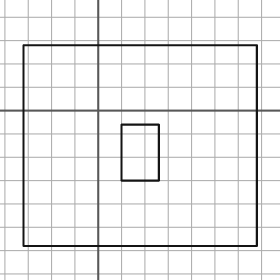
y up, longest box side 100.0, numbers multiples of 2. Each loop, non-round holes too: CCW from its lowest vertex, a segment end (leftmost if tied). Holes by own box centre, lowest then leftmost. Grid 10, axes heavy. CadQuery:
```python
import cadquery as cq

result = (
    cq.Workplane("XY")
    .moveTo(-32.0, -58.0)
    .lineTo(68.0, -58.0)
    .lineTo(68.0, 28.0)
    .lineTo(-32.0, 28.0)
    .close()
    .moveTo(10.0, -30.0)
    .lineTo(26.0, -30.0)
    .lineTo(26.0, -6.0)
    .lineTo(10.0, -6.0)
    .close()
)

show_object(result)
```